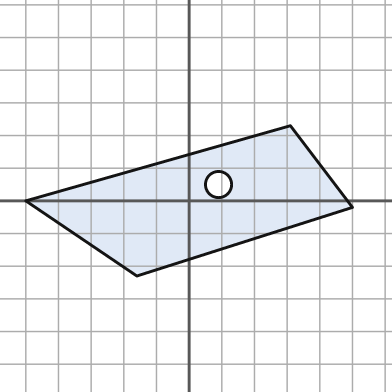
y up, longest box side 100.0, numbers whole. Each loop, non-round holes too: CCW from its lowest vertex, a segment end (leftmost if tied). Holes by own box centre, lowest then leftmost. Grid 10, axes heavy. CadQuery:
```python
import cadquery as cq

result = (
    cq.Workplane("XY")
    .moveTo(-16.0, -23.0)
    .lineTo(50.0, -2.0)
    .lineTo(31.0, 23.0)
    .lineTo(-50.0, 0.0)
    .close()
    .moveTo(9.0, 5.0)
    .circle(4.0)
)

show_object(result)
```